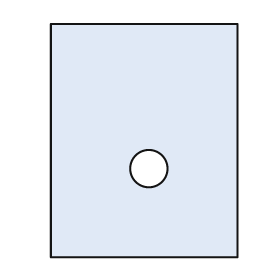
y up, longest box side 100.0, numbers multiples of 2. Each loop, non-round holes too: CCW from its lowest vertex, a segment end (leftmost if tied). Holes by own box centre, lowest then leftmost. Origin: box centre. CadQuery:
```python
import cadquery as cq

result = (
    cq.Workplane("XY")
    .moveTo(-40.0, -50.0)
    .lineTo(40.0, -50.0)
    .lineTo(40.0, 50.0)
    .lineTo(-40.0, 50.0)
    .close()
    .moveTo(2.0, -12.0)
    .circle(8.0)
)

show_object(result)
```